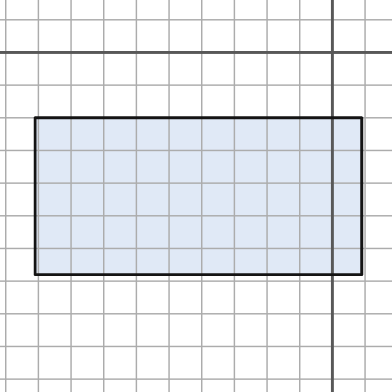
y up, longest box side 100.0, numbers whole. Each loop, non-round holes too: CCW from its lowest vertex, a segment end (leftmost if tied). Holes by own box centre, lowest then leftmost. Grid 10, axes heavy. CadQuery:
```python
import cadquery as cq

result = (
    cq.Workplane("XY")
    .moveTo(-91.0, -68.0)
    .lineTo(9.0, -68.0)
    .lineTo(9.0, -20.0)
    .lineTo(-91.0, -20.0)
    .close()
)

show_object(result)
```